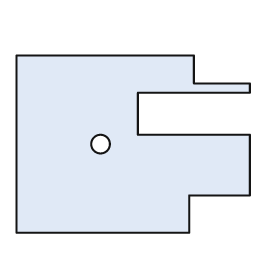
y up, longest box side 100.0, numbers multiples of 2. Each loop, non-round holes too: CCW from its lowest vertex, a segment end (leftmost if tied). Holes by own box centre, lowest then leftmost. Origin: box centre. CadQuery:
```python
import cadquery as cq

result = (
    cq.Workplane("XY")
    .moveTo(-50.0, -38.0)
    .lineTo(24.0, -38.0)
    .lineTo(24.0, -22.0)
    .lineTo(50.0, -22.0)
    .lineTo(50.0, 4.0)
    .lineTo(2.0, 4.0)
    .lineTo(2.0, 22.0)
    .lineTo(50.0, 22.0)
    .lineTo(50.0, 26.0)
    .lineTo(26.0, 26.0)
    .lineTo(26.0, 38.0)
    .lineTo(-50.0, 38.0)
    .close()
    .moveTo(-14.0, 0.0)
    .circle(4.0)
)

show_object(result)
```